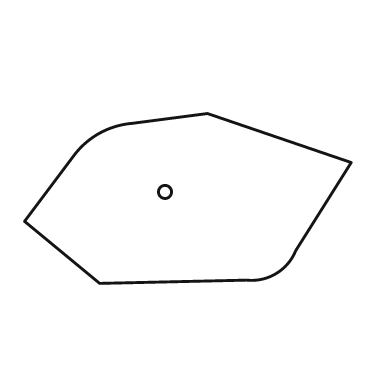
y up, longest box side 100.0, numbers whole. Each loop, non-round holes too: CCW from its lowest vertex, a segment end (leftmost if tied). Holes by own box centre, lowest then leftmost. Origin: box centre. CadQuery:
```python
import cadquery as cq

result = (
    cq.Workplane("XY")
    .moveTo(-27.0, -26.0)
    .lineTo(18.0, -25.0)
    .threePointArc((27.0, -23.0), (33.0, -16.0))
    .lineTo(50.0, 11.0)
    .lineTo(6.0, 26.0)
    .lineTo(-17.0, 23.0)
    .threePointArc((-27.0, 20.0), (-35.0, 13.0))
    .lineTo(-50.0, -7.0)
    .close()
    .moveTo(-7.0, 2.0)
    .circle(2.0)
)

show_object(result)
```